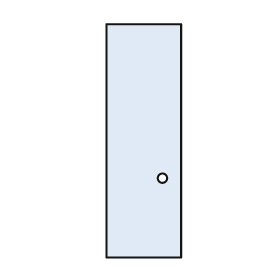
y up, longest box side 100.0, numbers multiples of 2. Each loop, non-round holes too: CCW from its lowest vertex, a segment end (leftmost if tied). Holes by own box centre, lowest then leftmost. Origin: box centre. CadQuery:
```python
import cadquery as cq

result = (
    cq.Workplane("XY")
    .moveTo(-16.0, -50.0)
    .lineTo(16.0, -50.0)
    .lineTo(16.0, 50.0)
    .lineTo(-16.0, 50.0)
    .close()
    .moveTo(8.0, -16.0)
    .circle(2.0)
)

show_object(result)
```